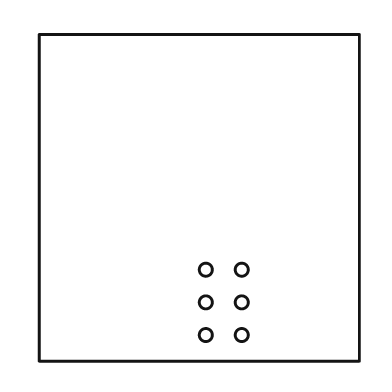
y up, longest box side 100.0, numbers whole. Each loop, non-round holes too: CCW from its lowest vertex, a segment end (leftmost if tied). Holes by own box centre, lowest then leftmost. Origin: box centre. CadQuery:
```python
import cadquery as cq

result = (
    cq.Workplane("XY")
    .moveTo(-49.0, -50.0)
    .lineTo(49.0, -50.0)
    .lineTo(49.0, 50.0)
    .lineTo(-49.0, 50.0)
    .close()
    .moveTo(2.0, -42.0)
    .circle(2.0)
    .moveTo(13.0, -42.0)
    .circle(2.0)
    .moveTo(2.0, -32.0)
    .circle(2.0)
    .moveTo(13.0, -32.0)
    .circle(2.0)
    .moveTo(2.0, -22.0)
    .circle(2.0)
    .moveTo(13.0, -22.0)
    .circle(2.0)
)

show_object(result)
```